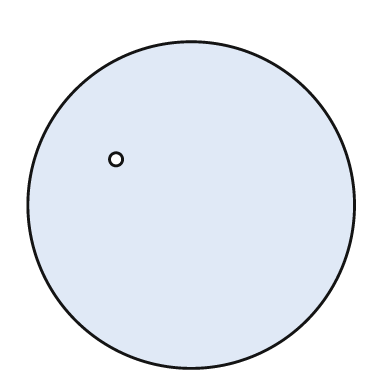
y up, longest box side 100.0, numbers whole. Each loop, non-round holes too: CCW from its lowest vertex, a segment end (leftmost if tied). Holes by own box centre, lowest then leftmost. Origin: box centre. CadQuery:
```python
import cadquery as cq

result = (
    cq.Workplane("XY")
    .moveTo(0.0, 0.0)
    .circle(50.0)
    .moveTo(-23.0, 14.0)
    .circle(2.0)
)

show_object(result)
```